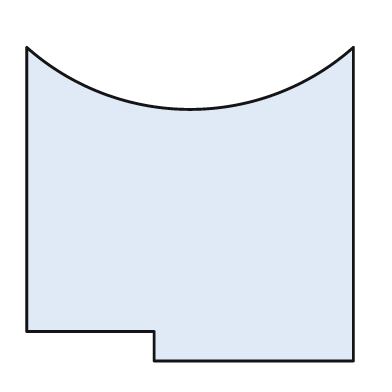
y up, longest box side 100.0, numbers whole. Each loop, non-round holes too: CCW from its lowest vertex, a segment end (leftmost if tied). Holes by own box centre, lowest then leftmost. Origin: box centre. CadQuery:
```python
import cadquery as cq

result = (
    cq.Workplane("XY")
    .moveTo(-11.0, -48.0)
    .lineTo(50.0, -48.0)
    .lineTo(50.0, 48.0)
    .threePointArc((0.0, 29.0), (-50.0, 48.0))
    .lineTo(-50.0, -39.0)
    .lineTo(-11.0, -39.0)
    .close()
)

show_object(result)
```